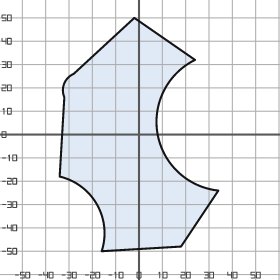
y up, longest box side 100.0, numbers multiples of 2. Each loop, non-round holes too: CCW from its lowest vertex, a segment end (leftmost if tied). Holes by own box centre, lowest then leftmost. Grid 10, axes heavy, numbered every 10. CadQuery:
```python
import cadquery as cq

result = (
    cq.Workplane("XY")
    .moveTo(-16.0, -50.0)
    .lineTo(18.0, -48.0)
    .lineTo(34.0, -24.0)
    .threePointArc((8.0, 0.0), (24.0, 32.0))
    .lineTo(-2.0, 50.0)
    .lineTo(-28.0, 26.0)
    .threePointArc((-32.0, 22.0), (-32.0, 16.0))
    .lineTo(-34.0, -18.0)
    .threePointArc((-18.0, -30.0), (-16.0, -50.0))
    .close()
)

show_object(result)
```